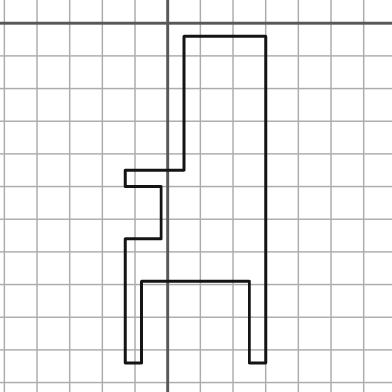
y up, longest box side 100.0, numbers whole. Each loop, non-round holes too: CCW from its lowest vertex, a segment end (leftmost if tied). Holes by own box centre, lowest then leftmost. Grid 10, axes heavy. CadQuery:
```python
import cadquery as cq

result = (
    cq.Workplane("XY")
    .moveTo(-13.0, -104.0)
    .lineTo(-8.0, -104.0)
    .lineTo(-8.0, -79.0)
    .lineTo(25.0, -79.0)
    .lineTo(25.0, -104.0)
    .lineTo(30.0, -104.0)
    .lineTo(30.0, -4.0)
    .lineTo(5.0, -4.0)
    .lineTo(5.0, -45.0)
    .lineTo(-13.0, -45.0)
    .lineTo(-13.0, -50.0)
    .lineTo(-2.0, -50.0)
    .lineTo(-2.0, -66.0)
    .lineTo(-13.0, -66.0)
    .close()
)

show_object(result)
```